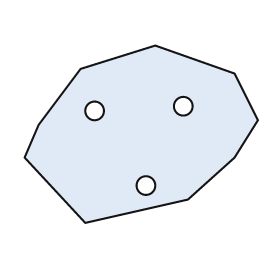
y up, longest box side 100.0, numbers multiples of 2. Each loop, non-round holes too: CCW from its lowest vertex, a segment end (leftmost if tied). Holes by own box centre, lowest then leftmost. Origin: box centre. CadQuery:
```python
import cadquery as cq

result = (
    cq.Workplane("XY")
    .moveTo(-24.0, -38.0)
    .lineTo(20.0, -28.0)
    .lineTo(40.0, -10.0)
    .lineTo(50.0, 6.0)
    .lineTo(40.0, 26.0)
    .lineTo(6.0, 38.0)
    .lineTo(-26.0, 28.0)
    .lineTo(-44.0, 4.0)
    .lineTo(-50.0, -10.0)
    .close()
    .moveTo(2.0, -22.0)
    .circle(4.0)
    .moveTo(-20.0, 10.0)
    .circle(4.0)
    .moveTo(18.0, 12.0)
    .circle(4.0)
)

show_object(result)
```